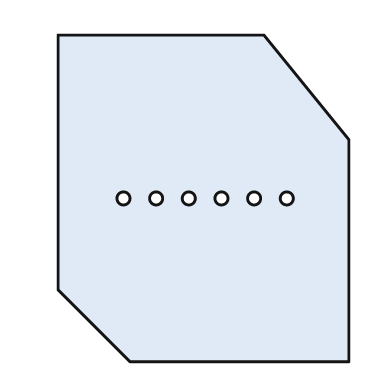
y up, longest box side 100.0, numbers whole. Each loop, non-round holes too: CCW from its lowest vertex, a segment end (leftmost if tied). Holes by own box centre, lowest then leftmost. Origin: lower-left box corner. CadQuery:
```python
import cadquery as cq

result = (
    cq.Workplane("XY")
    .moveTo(22.0, 0.0)
    .lineTo(89.0, 0.0)
    .lineTo(89.0, 68.0)
    .lineTo(63.0, 100.0)
    .lineTo(0.0, 100.0)
    .lineTo(0.0, 22.0)
    .close()
    .moveTo(20.0, 50.0)
    .circle(2.0)
    .moveTo(30.0, 50.0)
    .circle(2.0)
    .moveTo(40.0, 50.0)
    .circle(2.0)
    .moveTo(50.0, 50.0)
    .circle(2.0)
    .moveTo(60.0, 50.0)
    .circle(2.0)
    .moveTo(70.0, 50.0)
    .circle(2.0)
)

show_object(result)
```